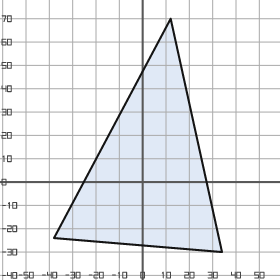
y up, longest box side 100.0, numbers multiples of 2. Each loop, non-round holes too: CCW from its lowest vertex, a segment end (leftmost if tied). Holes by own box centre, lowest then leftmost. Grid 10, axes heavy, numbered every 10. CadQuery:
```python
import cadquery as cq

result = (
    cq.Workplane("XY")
    .moveTo(34.0, -30.0)
    .lineTo(12.0, 70.0)
    .lineTo(-38.0, -24.0)
    .close()
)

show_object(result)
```